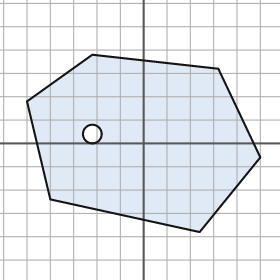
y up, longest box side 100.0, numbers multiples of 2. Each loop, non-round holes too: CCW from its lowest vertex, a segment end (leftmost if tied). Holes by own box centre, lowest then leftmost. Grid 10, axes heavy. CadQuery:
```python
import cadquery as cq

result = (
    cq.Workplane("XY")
    .moveTo(24.0, -38.0)
    .lineTo(50.0, -6.0)
    .lineTo(32.0, 32.0)
    .lineTo(-22.0, 38.0)
    .lineTo(-50.0, 18.0)
    .lineTo(-40.0, -24.0)
    .close()
    .moveTo(-22.0, 4.0)
    .circle(4.0)
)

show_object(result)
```